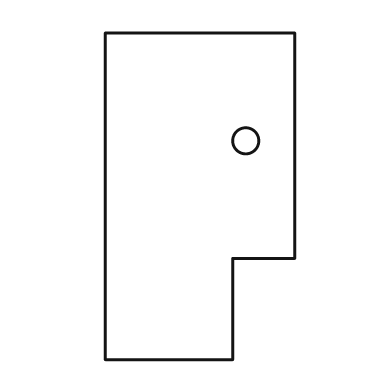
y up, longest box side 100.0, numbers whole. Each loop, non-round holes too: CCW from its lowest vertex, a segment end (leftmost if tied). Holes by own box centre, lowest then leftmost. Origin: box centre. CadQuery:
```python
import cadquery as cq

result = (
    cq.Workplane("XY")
    .moveTo(-29.0, -50.0)
    .lineTo(10.0, -50.0)
    .lineTo(10.0, -19.0)
    .lineTo(29.0, -19.0)
    .lineTo(29.0, 50.0)
    .lineTo(-29.0, 50.0)
    .close()
    .moveTo(14.0, 17.0)
    .circle(4.0)
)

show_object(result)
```